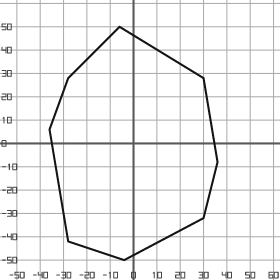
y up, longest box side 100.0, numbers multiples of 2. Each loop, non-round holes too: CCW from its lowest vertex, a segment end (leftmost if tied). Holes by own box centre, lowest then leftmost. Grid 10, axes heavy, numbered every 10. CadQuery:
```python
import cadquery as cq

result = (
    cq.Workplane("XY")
    .moveTo(-4.0, -50.0)
    .lineTo(30.0, -32.0)
    .lineTo(36.0, -8.0)
    .lineTo(30.0, 28.0)
    .lineTo(-6.0, 50.0)
    .lineTo(-28.0, 28.0)
    .lineTo(-36.0, 6.0)
    .lineTo(-28.0, -42.0)
    .close()
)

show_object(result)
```